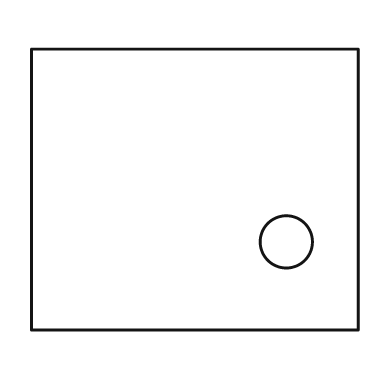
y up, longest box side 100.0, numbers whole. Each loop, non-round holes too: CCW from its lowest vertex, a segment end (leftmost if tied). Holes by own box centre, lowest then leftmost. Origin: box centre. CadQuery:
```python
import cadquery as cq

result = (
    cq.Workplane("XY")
    .moveTo(-50.0, -43.0)
    .lineTo(50.0, -43.0)
    .lineTo(50.0, 43.0)
    .lineTo(-50.0, 43.0)
    .close()
    .moveTo(28.0, -16.0)
    .circle(8.0)
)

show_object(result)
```